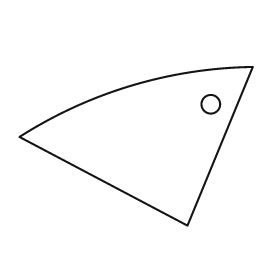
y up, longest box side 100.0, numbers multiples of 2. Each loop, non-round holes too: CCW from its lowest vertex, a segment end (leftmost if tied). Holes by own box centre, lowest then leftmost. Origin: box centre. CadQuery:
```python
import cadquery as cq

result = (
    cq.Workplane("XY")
    .moveTo(22.0, -34.0)
    .lineTo(50.0, 34.0)
    .threePointArc((-2.0, 26.0), (-50.0, 4.0))
    .close()
    .moveTo(32.0, 18.0)
    .circle(4.0)
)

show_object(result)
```